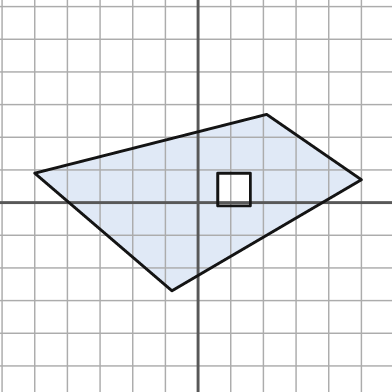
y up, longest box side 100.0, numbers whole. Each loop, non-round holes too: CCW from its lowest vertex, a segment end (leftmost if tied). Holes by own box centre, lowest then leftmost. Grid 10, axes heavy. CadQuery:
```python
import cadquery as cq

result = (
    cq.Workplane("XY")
    .moveTo(-8.0, -27.0)
    .lineTo(50.0, 7.0)
    .lineTo(21.0, 27.0)
    .lineTo(-50.0, 9.0)
    .close()
    .moveTo(6.0, -1.0)
    .lineTo(16.0, -1.0)
    .lineTo(16.0, 9.0)
    .lineTo(6.0, 9.0)
    .close()
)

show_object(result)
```